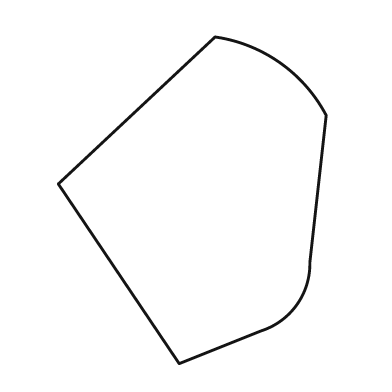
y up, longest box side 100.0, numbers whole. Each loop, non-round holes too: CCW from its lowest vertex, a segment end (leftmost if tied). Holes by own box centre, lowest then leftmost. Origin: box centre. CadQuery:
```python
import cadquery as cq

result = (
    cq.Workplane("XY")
    .moveTo(-4.0, -50.0)
    .lineTo(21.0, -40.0)
    .threePointArc((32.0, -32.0), (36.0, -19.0))
    .lineTo(41.0, 26.0)
    .threePointArc((27.0, 42.0), (7.0, 50.0))
    .lineTo(-41.0, 5.0)
    .close()
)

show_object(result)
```